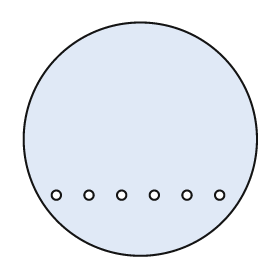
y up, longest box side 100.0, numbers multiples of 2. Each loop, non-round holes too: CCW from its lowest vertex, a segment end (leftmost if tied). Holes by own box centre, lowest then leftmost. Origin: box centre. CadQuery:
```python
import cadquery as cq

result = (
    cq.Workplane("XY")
    .moveTo(0.0, 0.0)
    .circle(50.0)
    .moveTo(-36.0, -24.0)
    .circle(2.0)
    .moveTo(-22.0, -24.0)
    .circle(2.0)
    .moveTo(-8.0, -24.0)
    .circle(2.0)
    .moveTo(6.0, -24.0)
    .circle(2.0)
    .moveTo(20.0, -24.0)
    .circle(2.0)
    .moveTo(34.0, -24.0)
    .circle(2.0)
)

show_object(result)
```